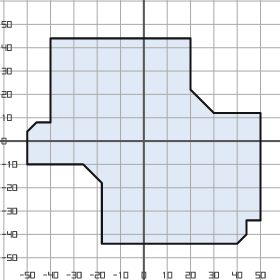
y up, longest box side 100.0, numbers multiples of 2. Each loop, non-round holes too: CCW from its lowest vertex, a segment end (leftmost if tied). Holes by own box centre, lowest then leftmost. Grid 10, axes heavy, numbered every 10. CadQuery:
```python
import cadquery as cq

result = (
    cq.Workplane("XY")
    .moveTo(-18.0, -44.0)
    .lineTo(40.0, -44.0)
    .lineTo(44.0, -40.0)
    .lineTo(44.0, -34.0)
    .lineTo(50.0, -34.0)
    .lineTo(50.0, 12.0)
    .lineTo(30.0, 12.0)
    .lineTo(20.0, 22.0)
    .lineTo(20.0, 44.0)
    .lineTo(-40.0, 44.0)
    .lineTo(-40.0, 8.0)
    .lineTo(-46.0, 8.0)
    .lineTo(-50.0, 4.0)
    .lineTo(-50.0, -10.0)
    .lineTo(-26.0, -10.0)
    .lineTo(-18.0, -18.0)
    .close()
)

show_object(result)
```